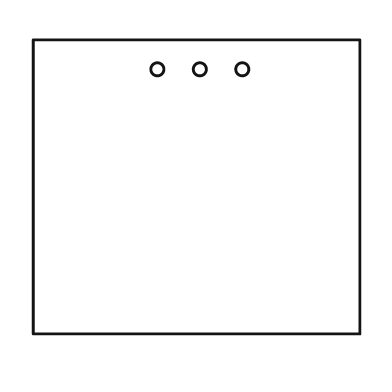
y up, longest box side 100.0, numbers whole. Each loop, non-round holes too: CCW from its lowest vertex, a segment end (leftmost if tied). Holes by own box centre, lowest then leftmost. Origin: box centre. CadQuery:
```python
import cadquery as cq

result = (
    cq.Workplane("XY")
    .moveTo(-50.0, -45.0)
    .lineTo(50.0, -45.0)
    .lineTo(50.0, 45.0)
    .lineTo(-50.0, 45.0)
    .close()
    .moveTo(-12.0, 36.0)
    .circle(2.0)
    .moveTo(1.0, 36.0)
    .circle(2.0)
    .moveTo(14.0, 36.0)
    .circle(2.0)
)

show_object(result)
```